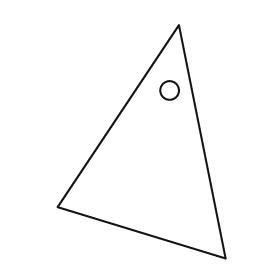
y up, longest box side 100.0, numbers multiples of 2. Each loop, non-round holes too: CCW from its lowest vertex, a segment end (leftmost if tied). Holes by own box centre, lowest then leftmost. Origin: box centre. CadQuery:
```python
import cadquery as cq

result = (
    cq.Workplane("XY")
    .moveTo(36.0, -50.0)
    .lineTo(16.0, 50.0)
    .lineTo(-36.0, -28.0)
    .close()
    .moveTo(12.0, 22.0)
    .circle(4.0)
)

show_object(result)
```